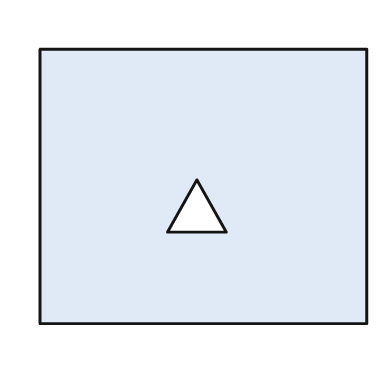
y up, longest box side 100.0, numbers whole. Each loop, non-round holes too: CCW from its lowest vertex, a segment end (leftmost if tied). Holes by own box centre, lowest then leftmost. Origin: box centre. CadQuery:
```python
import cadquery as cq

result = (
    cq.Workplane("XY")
    .moveTo(-50.0, -42.0)
    .lineTo(50.0, -42.0)
    .lineTo(50.0, 42.0)
    .lineTo(-50.0, 42.0)
    .close()
    .moveTo(-11.0, -14.0)
    .lineTo(7.0, -14.0)
    .lineTo(-2.0, 2.0)
    .close()
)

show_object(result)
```